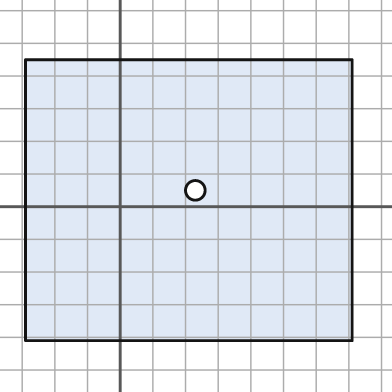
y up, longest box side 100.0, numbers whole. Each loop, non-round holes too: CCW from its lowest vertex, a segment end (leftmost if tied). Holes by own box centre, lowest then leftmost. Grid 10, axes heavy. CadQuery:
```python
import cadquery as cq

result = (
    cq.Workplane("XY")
    .moveTo(-29.0, -41.0)
    .lineTo(71.0, -41.0)
    .lineTo(71.0, 45.0)
    .lineTo(-29.0, 45.0)
    .close()
    .moveTo(23.0, 5.0)
    .circle(3.0)
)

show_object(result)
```